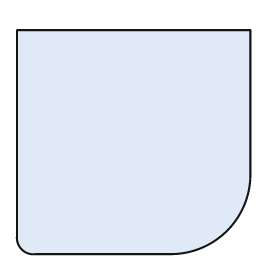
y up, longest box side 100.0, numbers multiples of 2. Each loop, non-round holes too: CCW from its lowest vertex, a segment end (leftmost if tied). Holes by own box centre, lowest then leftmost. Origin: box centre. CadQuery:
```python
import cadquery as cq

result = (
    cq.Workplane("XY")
    .moveTo(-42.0, -48.0)
    .lineTo(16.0, -48.0)
    .threePointArc((40.0, -38.0), (50.0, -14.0))
    .lineTo(50.0, 48.0)
    .lineTo(-50.0, 48.0)
    .lineTo(-50.0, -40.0)
    .threePointArc((-48.0, -46.0), (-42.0, -48.0))
    .close()
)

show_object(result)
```